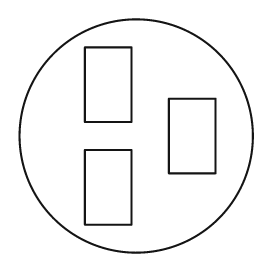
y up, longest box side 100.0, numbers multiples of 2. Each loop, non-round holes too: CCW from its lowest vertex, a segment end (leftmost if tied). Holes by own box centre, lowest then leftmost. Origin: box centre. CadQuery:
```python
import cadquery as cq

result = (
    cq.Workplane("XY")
    .moveTo(0.0, 0.0)
    .circle(50.0)
    .moveTo(-22.0, -38.0)
    .lineTo(-2.0, -38.0)
    .lineTo(-2.0, -6.0)
    .lineTo(-22.0, -6.0)
    .close()
    .moveTo(14.0, -16.0)
    .lineTo(34.0, -16.0)
    .lineTo(34.0, 16.0)
    .lineTo(14.0, 16.0)
    .close()
    .moveTo(-22.0, 6.0)
    .lineTo(-2.0, 6.0)
    .lineTo(-2.0, 38.0)
    .lineTo(-22.0, 38.0)
    .close()
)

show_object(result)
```